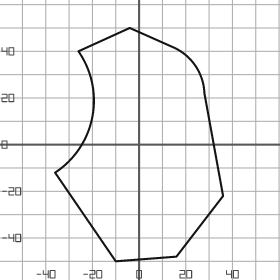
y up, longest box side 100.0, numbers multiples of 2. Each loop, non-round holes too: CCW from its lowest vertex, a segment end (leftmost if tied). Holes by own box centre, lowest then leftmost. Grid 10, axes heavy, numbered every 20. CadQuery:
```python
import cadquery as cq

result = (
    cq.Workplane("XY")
    .moveTo(-10.0, -50.0)
    .lineTo(16.0, -48.0)
    .lineTo(36.0, -22.0)
    .lineTo(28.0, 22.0)
    .threePointArc((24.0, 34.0), (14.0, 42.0))
    .lineTo(-4.0, 50.0)
    .lineTo(-26.0, 40.0)
    .threePointArc((-20.0, 12.0), (-36.0, -12.0))
    .close()
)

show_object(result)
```